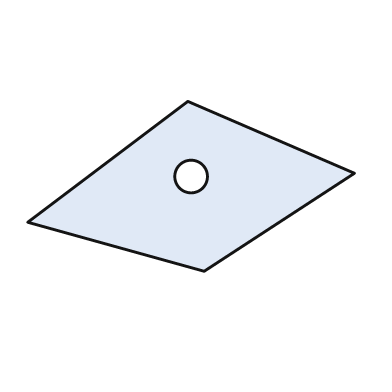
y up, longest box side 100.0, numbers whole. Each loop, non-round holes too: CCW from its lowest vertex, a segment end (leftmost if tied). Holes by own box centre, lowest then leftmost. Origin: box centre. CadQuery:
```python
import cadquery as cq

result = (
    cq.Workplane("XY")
    .moveTo(4.0, -26.0)
    .lineTo(50.0, 4.0)
    .lineTo(-1.0, 26.0)
    .lineTo(-50.0, -11.0)
    .close()
    .moveTo(0.0, 3.0)
    .circle(5.0)
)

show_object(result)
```